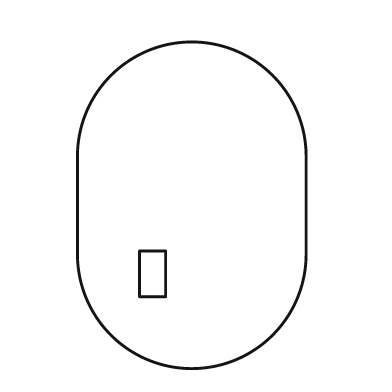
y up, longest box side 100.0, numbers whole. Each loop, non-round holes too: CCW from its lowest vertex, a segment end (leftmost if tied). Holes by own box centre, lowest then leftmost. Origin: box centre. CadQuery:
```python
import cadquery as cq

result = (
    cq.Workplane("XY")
    .moveTo(-35.0, -15.0)
    .threePointArc((0.0, -50.0), (35.0, -15.0))
    .lineTo(35.0, 15.0)
    .threePointArc((0.0, 50.0), (-35.0, 15.0))
    .close()
    .moveTo(-16.0, -28.0)
    .lineTo(-8.0, -28.0)
    .lineTo(-8.0, -14.0)
    .lineTo(-16.0, -14.0)
    .close()
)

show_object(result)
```